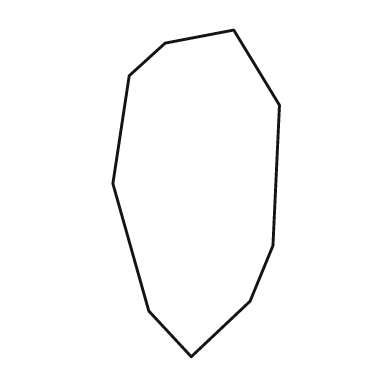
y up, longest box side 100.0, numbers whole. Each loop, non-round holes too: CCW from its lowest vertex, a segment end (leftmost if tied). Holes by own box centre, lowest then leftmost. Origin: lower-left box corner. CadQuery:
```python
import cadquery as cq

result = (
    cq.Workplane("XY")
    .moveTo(24.0, 0.0)
    .lineTo(42.0, 17.0)
    .lineTo(49.0, 34.0)
    .lineTo(51.0, 77.0)
    .lineTo(37.0, 100.0)
    .lineTo(16.0, 96.0)
    .lineTo(5.0, 86.0)
    .lineTo(0.0, 53.0)
    .lineTo(11.0, 14.0)
    .close()
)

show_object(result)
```